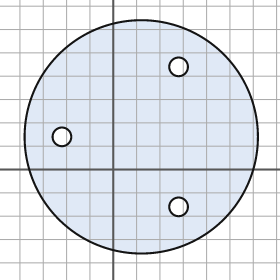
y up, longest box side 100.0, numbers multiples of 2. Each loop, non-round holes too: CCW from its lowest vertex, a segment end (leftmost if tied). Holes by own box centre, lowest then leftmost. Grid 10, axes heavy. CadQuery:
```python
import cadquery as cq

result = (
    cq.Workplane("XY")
    .moveTo(12.0, 14.0)
    .circle(50.0)
    .moveTo(28.0, -16.0)
    .circle(4.0)
    .moveTo(-22.0, 14.0)
    .circle(4.0)
    .moveTo(28.0, 44.0)
    .circle(4.0)
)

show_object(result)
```